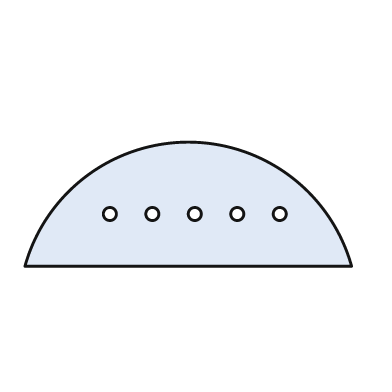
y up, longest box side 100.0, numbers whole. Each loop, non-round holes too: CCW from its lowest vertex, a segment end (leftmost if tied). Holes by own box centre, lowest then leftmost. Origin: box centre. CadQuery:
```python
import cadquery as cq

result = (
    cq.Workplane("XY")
    .moveTo(-50.0, -19.0)
    .lineTo(50.0, -19.0)
    .threePointArc((0.0, 19.0), (-50.0, -19.0))
    .close()
    .moveTo(-24.0, -3.0)
    .circle(2.0)
    .moveTo(-11.0, -3.0)
    .circle(2.0)
    .moveTo(2.0, -3.0)
    .circle(2.0)
    .moveTo(15.0, -3.0)
    .circle(2.0)
    .moveTo(28.0, -3.0)
    .circle(2.0)
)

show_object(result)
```